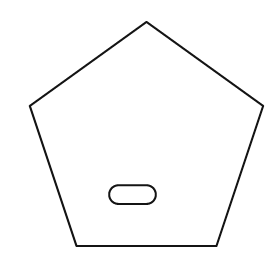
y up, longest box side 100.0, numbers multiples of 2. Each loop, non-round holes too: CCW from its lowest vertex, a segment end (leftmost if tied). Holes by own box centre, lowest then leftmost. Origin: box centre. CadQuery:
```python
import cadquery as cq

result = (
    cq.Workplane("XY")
    .moveTo(-30.0, -48.0)
    .lineTo(30.0, -48.0)
    .lineTo(50.0, 12.0)
    .lineTo(0.0, 48.0)
    .lineTo(-50.0, 12.0)
    .close()
    .moveTo(-12.0, -30.0)
    .lineTo(0.0, -30.0)
    .threePointArc((4.0, -26.0), (0.0, -22.0))
    .lineTo(-12.0, -22.0)
    .threePointArc((-16.0, -26.0), (-12.0, -30.0))
    .close()
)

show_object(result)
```